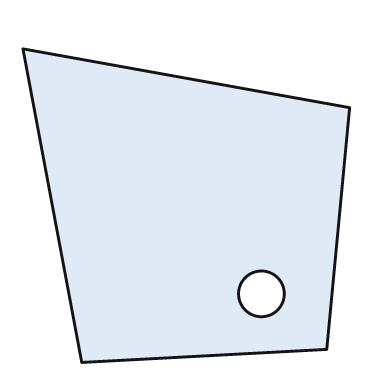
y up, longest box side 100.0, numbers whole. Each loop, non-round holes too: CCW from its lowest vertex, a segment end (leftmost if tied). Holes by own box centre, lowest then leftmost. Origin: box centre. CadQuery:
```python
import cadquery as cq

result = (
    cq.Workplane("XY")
    .moveTo(-32.0, -48.0)
    .lineTo(43.0, -44.0)
    .lineTo(50.0, 30.0)
    .lineTo(-50.0, 48.0)
    .close()
    .moveTo(23.0, -27.0)
    .circle(7.0)
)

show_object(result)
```